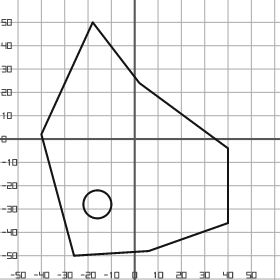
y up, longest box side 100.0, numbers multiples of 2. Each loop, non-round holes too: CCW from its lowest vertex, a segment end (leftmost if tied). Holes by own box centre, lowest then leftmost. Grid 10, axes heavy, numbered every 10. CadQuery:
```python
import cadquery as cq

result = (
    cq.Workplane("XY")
    .moveTo(-26.0, -50.0)
    .lineTo(6.0, -48.0)
    .lineTo(40.0, -36.0)
    .lineTo(40.0, -4.0)
    .lineTo(2.0, 24.0)
    .lineTo(-18.0, 50.0)
    .lineTo(-40.0, 2.0)
    .close()
    .moveTo(-16.0, -28.0)
    .circle(6.0)
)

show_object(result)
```